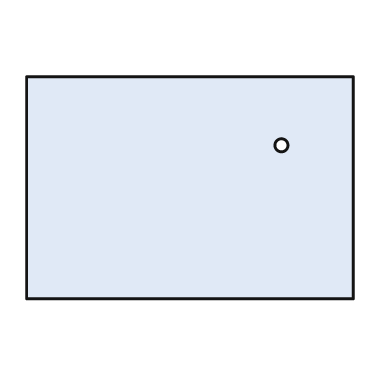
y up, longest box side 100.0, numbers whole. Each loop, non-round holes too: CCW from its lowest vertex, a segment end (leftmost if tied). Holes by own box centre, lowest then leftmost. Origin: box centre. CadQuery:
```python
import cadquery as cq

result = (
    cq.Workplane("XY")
    .moveTo(-50.0, -34.0)
    .lineTo(50.0, -34.0)
    .lineTo(50.0, 34.0)
    .lineTo(-50.0, 34.0)
    .close()
    .moveTo(28.0, 13.0)
    .circle(2.0)
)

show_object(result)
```